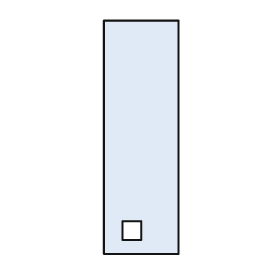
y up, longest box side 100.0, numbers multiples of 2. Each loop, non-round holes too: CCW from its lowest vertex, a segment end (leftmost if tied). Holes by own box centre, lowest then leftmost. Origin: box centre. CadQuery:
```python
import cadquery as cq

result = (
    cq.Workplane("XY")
    .moveTo(-16.0, -50.0)
    .lineTo(16.0, -50.0)
    .lineTo(16.0, 50.0)
    .lineTo(-16.0, 50.0)
    .close()
    .moveTo(-8.0, -44.0)
    .lineTo(0.0, -44.0)
    .lineTo(0.0, -36.0)
    .lineTo(-8.0, -36.0)
    .close()
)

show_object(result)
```